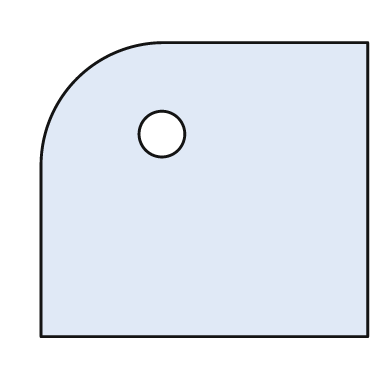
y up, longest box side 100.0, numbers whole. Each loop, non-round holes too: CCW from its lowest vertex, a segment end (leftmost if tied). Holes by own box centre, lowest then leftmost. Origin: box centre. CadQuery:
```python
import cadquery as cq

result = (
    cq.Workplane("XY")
    .moveTo(-50.0, -45.0)
    .lineTo(50.0, -45.0)
    .lineTo(50.0, 45.0)
    .lineTo(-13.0, 45.0)
    .threePointArc((-39.0, 34.0), (-50.0, 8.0))
    .close()
    .moveTo(-13.0, 17.0)
    .circle(7.0)
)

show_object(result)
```